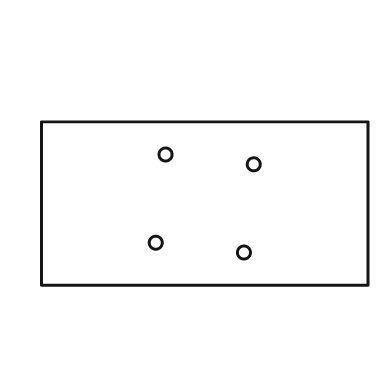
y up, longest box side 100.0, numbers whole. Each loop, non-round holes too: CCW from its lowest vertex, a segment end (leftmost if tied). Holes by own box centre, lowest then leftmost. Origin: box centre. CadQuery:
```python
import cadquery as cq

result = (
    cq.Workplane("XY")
    .moveTo(-50.0, -25.0)
    .lineTo(50.0, -25.0)
    .lineTo(50.0, 25.0)
    .lineTo(-50.0, 25.0)
    .close()
    .moveTo(12.0, -15.0)
    .circle(2.0)
    .moveTo(-15.0, -12.0)
    .circle(2.0)
    .moveTo(15.0, 12.0)
    .circle(2.0)
    .moveTo(-12.0, 15.0)
    .circle(2.0)
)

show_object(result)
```